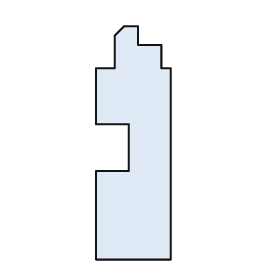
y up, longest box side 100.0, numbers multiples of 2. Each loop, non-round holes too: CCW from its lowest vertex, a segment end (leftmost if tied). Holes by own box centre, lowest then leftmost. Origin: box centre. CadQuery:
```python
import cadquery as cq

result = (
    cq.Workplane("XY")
    .moveTo(-16.0, -50.0)
    .lineTo(16.0, -50.0)
    .lineTo(16.0, 32.0)
    .lineTo(12.0, 32.0)
    .lineTo(12.0, 42.0)
    .lineTo(2.0, 42.0)
    .lineTo(2.0, 50.0)
    .lineTo(-4.0, 50.0)
    .lineTo(-8.0, 46.0)
    .lineTo(-8.0, 32.0)
    .lineTo(-16.0, 32.0)
    .lineTo(-16.0, 8.0)
    .lineTo(-2.0, 8.0)
    .lineTo(-2.0, -12.0)
    .lineTo(-16.0, -12.0)
    .close()
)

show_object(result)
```